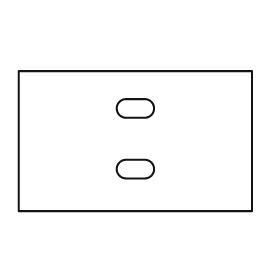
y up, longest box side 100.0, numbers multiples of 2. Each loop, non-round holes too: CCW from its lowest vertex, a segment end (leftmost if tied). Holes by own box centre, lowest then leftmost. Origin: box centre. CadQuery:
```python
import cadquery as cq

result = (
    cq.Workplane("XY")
    .moveTo(-50.0, -30.0)
    .lineTo(50.0, -30.0)
    .lineTo(50.0, 30.0)
    .lineTo(-50.0, 30.0)
    .close()
    .moveTo(-4.0, -16.0)
    .lineTo(4.0, -16.0)
    .threePointArc((8.0, -12.0), (4.0, -8.0))
    .lineTo(-4.0, -8.0)
    .threePointArc((-8.0, -12.0), (-4.0, -16.0))
    .close()
    .moveTo(-4.0, 10.0)
    .lineTo(4.0, 10.0)
    .threePointArc((8.0, 14.0), (4.0, 18.0))
    .lineTo(-4.0, 18.0)
    .threePointArc((-8.0, 14.0), (-4.0, 10.0))
    .close()
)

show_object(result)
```